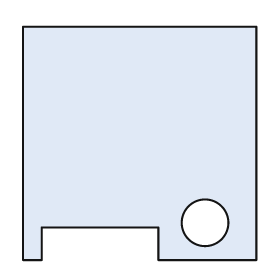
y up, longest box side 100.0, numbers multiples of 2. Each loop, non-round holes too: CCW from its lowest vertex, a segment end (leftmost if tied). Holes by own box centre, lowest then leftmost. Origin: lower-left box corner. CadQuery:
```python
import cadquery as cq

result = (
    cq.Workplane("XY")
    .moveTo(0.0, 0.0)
    .lineTo(8.0, 0.0)
    .lineTo(8.0, 14.0)
    .lineTo(58.0, 14.0)
    .lineTo(58.0, 0.0)
    .lineTo(100.0, 0.0)
    .lineTo(100.0, 100.0)
    .lineTo(0.0, 100.0)
    .close()
    .moveTo(78.0, 16.0)
    .circle(10.0)
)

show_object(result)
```